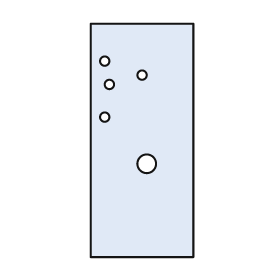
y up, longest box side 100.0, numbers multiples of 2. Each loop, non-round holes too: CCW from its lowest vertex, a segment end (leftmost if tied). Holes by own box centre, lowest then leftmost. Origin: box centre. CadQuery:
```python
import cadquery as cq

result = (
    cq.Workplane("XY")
    .moveTo(-22.0, -50.0)
    .lineTo(22.0, -50.0)
    .lineTo(22.0, 50.0)
    .lineTo(-22.0, 50.0)
    .close()
    .moveTo(2.0, -10.0)
    .circle(4.0)
    .moveTo(-16.0, 10.0)
    .circle(2.0)
    .moveTo(-14.0, 24.0)
    .circle(2.0)
    .moveTo(0.0, 28.0)
    .circle(2.0)
    .moveTo(-16.0, 34.0)
    .circle(2.0)
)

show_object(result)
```